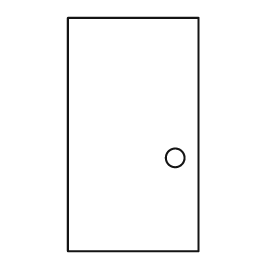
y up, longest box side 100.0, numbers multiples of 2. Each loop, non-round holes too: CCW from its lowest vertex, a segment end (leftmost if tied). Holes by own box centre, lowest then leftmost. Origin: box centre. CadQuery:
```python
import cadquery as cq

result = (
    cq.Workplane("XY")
    .moveTo(-28.0, -50.0)
    .lineTo(28.0, -50.0)
    .lineTo(28.0, 50.0)
    .lineTo(-28.0, 50.0)
    .close()
    .moveTo(18.0, -10.0)
    .circle(4.0)
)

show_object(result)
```